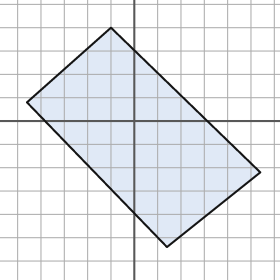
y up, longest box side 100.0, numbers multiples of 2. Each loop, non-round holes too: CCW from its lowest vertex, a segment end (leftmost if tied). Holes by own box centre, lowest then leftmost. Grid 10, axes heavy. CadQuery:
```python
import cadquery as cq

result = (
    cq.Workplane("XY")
    .moveTo(14.0, -54.0)
    .lineTo(54.0, -22.0)
    .lineTo(-10.0, 40.0)
    .lineTo(-46.0, 8.0)
    .close()
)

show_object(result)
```